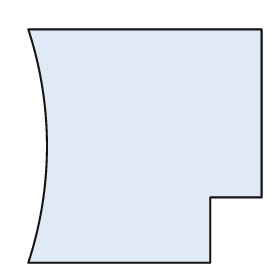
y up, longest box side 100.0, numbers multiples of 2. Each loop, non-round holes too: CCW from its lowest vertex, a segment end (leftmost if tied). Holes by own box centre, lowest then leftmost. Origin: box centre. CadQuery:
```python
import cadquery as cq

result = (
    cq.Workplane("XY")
    .moveTo(-50.0, -50.0)
    .lineTo(28.0, -50.0)
    .lineTo(28.0, -22.0)
    .lineTo(50.0, -22.0)
    .lineTo(50.0, 50.0)
    .lineTo(-50.0, 50.0)
    .threePointArc((-42.0, 0.0), (-50.0, -50.0))
    .close()
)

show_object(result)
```